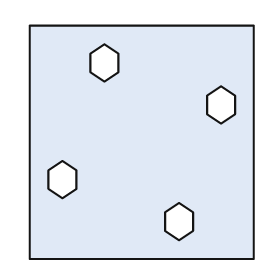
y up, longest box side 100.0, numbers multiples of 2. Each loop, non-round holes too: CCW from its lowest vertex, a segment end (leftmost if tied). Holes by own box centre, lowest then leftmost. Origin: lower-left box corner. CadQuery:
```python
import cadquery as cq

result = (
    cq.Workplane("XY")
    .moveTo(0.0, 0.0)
    .lineTo(96.0, 0.0)
    .lineTo(96.0, 100.0)
    .lineTo(0.0, 100.0)
    .close()
    .moveTo(64.0, 8.0)
    .lineTo(70.0, 12.0)
    .lineTo(70.0, 20.0)
    .lineTo(64.0, 24.0)
    .lineTo(58.0, 20.0)
    .lineTo(58.0, 12.0)
    .close()
    .moveTo(14.0, 26.0)
    .lineTo(20.0, 30.0)
    .lineTo(20.0, 38.0)
    .lineTo(14.0, 42.0)
    .lineTo(8.0, 38.0)
    .lineTo(8.0, 30.0)
    .close()
    .moveTo(82.0, 58.0)
    .lineTo(88.0, 62.0)
    .lineTo(88.0, 70.0)
    .lineTo(82.0, 74.0)
    .lineTo(76.0, 70.0)
    .lineTo(76.0, 62.0)
    .close()
    .moveTo(32.0, 76.0)
    .lineTo(38.0, 80.0)
    .lineTo(38.0, 88.0)
    .lineTo(32.0, 92.0)
    .lineTo(26.0, 88.0)
    .lineTo(26.0, 80.0)
    .close()
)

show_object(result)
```